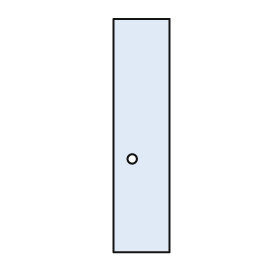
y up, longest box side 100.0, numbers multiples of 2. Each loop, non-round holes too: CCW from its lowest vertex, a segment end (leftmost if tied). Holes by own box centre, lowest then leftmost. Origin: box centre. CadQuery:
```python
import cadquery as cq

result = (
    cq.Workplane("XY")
    .moveTo(-12.0, -50.0)
    .lineTo(12.0, -50.0)
    .lineTo(12.0, 50.0)
    .lineTo(-12.0, 50.0)
    .close()
    .moveTo(-4.0, -10.0)
    .circle(2.0)
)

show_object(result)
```